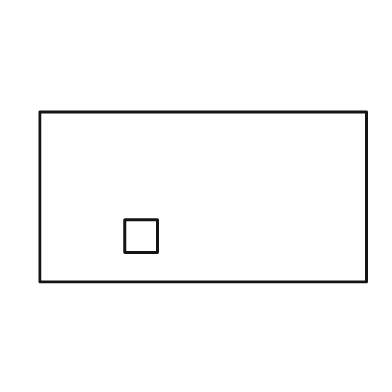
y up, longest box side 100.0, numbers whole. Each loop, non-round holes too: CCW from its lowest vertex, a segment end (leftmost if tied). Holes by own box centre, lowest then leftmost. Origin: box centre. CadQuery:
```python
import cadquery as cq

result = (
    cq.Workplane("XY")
    .moveTo(-50.0, -26.0)
    .lineTo(50.0, -26.0)
    .lineTo(50.0, 26.0)
    .lineTo(-50.0, 26.0)
    .close()
    .moveTo(-24.0, -17.0)
    .lineTo(-14.0, -17.0)
    .lineTo(-14.0, -7.0)
    .lineTo(-24.0, -7.0)
    .close()
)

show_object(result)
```